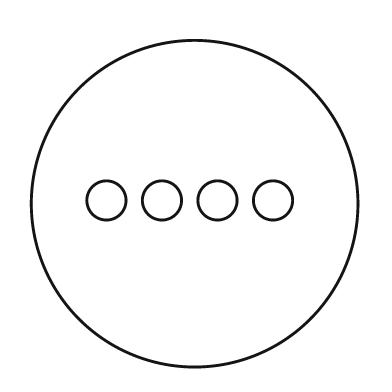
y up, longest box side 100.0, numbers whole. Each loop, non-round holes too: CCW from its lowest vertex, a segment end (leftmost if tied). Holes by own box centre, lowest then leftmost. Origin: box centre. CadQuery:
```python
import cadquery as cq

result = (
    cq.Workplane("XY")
    .moveTo(0.0, 0.0)
    .circle(50.0)
    .moveTo(-27.0, 1.0)
    .circle(6.0)
    .moveTo(-10.0, 1.0)
    .circle(6.0)
    .moveTo(7.0, 1.0)
    .circle(6.0)
    .moveTo(24.0, 1.0)
    .circle(6.0)
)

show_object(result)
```